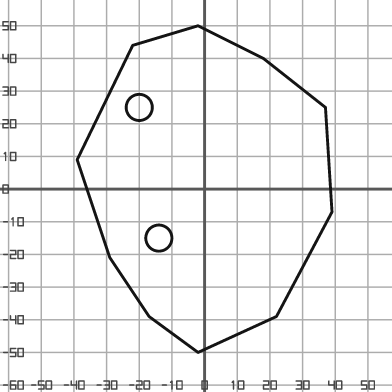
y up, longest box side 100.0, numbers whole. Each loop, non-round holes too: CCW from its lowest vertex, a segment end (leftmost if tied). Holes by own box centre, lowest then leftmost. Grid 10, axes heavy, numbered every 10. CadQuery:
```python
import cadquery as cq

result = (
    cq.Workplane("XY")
    .moveTo(-2.0, -50.0)
    .lineTo(22.0, -39.0)
    .lineTo(39.0, -7.0)
    .lineTo(37.0, 25.0)
    .lineTo(18.0, 40.0)
    .lineTo(-2.0, 50.0)
    .lineTo(-22.0, 44.0)
    .lineTo(-39.0, 9.0)
    .lineTo(-29.0, -21.0)
    .lineTo(-17.0, -39.0)
    .close()
    .moveTo(-14.0, -15.0)
    .circle(4.0)
    .moveTo(-20.0, 25.0)
    .circle(4.0)
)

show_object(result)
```